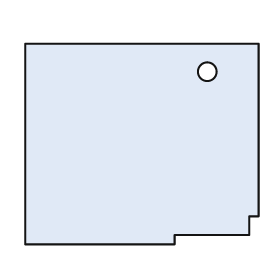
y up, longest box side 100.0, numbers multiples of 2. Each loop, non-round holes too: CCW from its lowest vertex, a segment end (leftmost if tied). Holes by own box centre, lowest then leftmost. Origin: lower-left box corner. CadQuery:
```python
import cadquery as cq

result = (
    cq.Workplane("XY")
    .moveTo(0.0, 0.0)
    .lineTo(64.0, 0.0)
    .lineTo(64.0, 4.0)
    .lineTo(96.0, 4.0)
    .lineTo(96.0, 12.0)
    .lineTo(100.0, 12.0)
    .lineTo(100.0, 86.0)
    .lineTo(0.0, 86.0)
    .close()
    .moveTo(78.0, 74.0)
    .circle(4.0)
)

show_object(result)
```